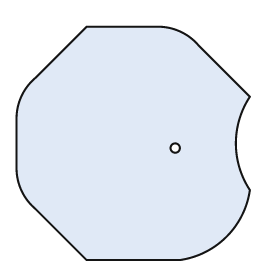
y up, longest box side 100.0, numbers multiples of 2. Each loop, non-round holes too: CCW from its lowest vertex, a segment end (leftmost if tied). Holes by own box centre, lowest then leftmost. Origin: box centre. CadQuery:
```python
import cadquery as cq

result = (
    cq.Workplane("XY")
    .moveTo(-20.0, -50.0)
    .lineTo(20.0, -50.0)
    .threePointArc((40.0, -40.0), (50.0, -20.0))
    .threePointArc((44.0, 0.0), (50.0, 20.0))
    .lineTo(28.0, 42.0)
    .threePointArc((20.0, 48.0), (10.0, 50.0))
    .lineTo(-20.0, 50.0)
    .lineTo(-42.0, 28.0)
    .threePointArc((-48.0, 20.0), (-50.0, 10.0))
    .lineTo(-50.0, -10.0)
    .threePointArc((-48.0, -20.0), (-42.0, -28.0))
    .close()
    .moveTo(18.0, -2.0)
    .circle(2.0)
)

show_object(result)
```